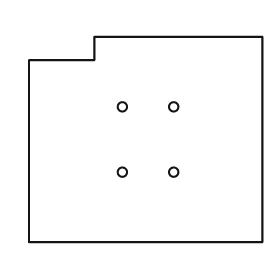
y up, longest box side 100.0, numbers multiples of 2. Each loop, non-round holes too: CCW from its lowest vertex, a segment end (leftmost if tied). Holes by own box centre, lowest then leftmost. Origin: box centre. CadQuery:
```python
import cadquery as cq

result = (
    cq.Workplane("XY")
    .moveTo(-50.0, -44.0)
    .lineTo(50.0, -44.0)
    .lineTo(50.0, 44.0)
    .lineTo(-22.0, 44.0)
    .lineTo(-22.0, 34.0)
    .lineTo(-50.0, 34.0)
    .close()
    .moveTo(-10.0, -14.0)
    .circle(2.0)
    .moveTo(12.0, -14.0)
    .circle(2.0)
    .moveTo(-10.0, 14.0)
    .circle(2.0)
    .moveTo(12.0, 14.0)
    .circle(2.0)
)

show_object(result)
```